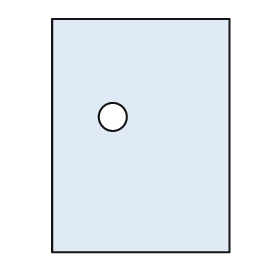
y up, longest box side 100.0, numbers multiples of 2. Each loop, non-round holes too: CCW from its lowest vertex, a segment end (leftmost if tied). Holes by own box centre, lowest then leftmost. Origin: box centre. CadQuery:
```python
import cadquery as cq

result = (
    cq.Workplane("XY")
    .moveTo(-38.0, -50.0)
    .lineTo(38.0, -50.0)
    .lineTo(38.0, 50.0)
    .lineTo(-38.0, 50.0)
    .close()
    .moveTo(-12.0, 8.0)
    .circle(6.0)
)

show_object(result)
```